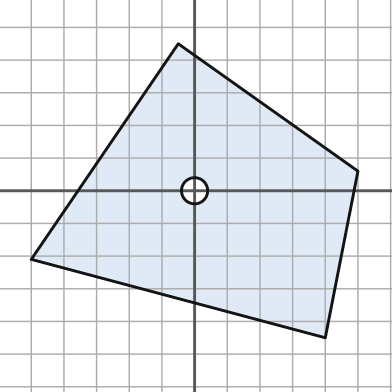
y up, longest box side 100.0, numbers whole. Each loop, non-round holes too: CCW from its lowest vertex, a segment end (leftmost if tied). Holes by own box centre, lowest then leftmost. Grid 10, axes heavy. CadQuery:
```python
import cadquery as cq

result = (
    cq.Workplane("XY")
    .moveTo(40.0, -45.0)
    .lineTo(50.0, 6.0)
    .lineTo(-5.0, 45.0)
    .lineTo(-50.0, -21.0)
    .close()
    .moveTo(0.0, 0.0)
    .circle(4.0)
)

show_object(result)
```